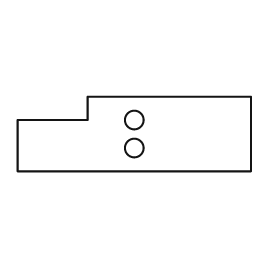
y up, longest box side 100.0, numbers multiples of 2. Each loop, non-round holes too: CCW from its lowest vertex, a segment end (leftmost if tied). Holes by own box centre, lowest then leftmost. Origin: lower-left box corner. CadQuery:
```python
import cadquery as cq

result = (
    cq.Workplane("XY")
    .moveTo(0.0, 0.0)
    .lineTo(100.0, 0.0)
    .lineTo(100.0, 32.0)
    .lineTo(30.0, 32.0)
    .lineTo(30.0, 22.0)
    .lineTo(0.0, 22.0)
    .close()
    .moveTo(50.0, 10.0)
    .circle(4.0)
    .moveTo(50.0, 22.0)
    .circle(4.0)
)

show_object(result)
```